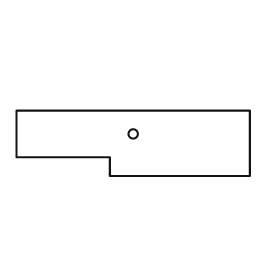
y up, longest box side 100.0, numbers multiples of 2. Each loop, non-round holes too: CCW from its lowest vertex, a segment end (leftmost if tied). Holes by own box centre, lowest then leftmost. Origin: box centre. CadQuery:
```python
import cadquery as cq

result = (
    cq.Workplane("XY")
    .moveTo(-10.0, -14.0)
    .lineTo(50.0, -14.0)
    .lineTo(50.0, 14.0)
    .lineTo(-50.0, 14.0)
    .lineTo(-50.0, -6.0)
    .lineTo(-10.0, -6.0)
    .close()
    .moveTo(0.0, 4.0)
    .circle(2.0)
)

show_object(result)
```